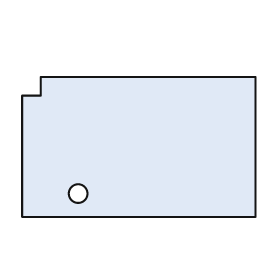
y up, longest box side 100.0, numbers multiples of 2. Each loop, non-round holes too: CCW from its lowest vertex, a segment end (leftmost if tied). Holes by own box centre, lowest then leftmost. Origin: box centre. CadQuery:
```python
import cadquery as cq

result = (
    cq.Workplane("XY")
    .moveTo(-50.0, -30.0)
    .lineTo(50.0, -30.0)
    .lineTo(50.0, 30.0)
    .lineTo(-42.0, 30.0)
    .lineTo(-42.0, 22.0)
    .lineTo(-50.0, 22.0)
    .close()
    .moveTo(-26.0, -20.0)
    .circle(4.0)
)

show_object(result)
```